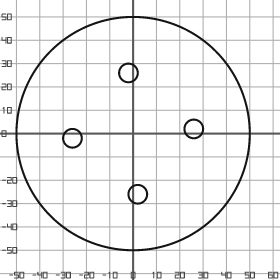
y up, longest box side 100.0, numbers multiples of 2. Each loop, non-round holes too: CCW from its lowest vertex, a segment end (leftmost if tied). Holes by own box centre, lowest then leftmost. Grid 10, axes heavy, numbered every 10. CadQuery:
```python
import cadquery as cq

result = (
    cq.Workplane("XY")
    .moveTo(0.0, 0.0)
    .circle(50.0)
    .moveTo(2.0, -26.0)
    .circle(4.0)
    .moveTo(-26.0, -2.0)
    .circle(4.0)
    .moveTo(26.0, 2.0)
    .circle(4.0)
    .moveTo(-2.0, 26.0)
    .circle(4.0)
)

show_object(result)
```